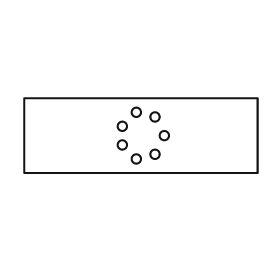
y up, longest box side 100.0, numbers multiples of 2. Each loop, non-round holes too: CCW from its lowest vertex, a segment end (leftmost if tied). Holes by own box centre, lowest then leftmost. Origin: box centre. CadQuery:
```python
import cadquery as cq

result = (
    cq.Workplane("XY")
    .moveTo(-50.0, -16.0)
    .lineTo(50.0, -16.0)
    .lineTo(50.0, 16.0)
    .lineTo(-50.0, 16.0)
    .close()
    .moveTo(-2.0, -10.0)
    .circle(2.0)
    .moveTo(6.0, -8.0)
    .circle(2.0)
    .moveTo(-8.0, -4.0)
    .circle(2.0)
    .moveTo(10.0, 0.0)
    .circle(2.0)
    .moveTo(-8.0, 4.0)
    .circle(2.0)
    .moveTo(6.0, 8.0)
    .circle(2.0)
    .moveTo(-2.0, 10.0)
    .circle(2.0)
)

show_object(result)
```